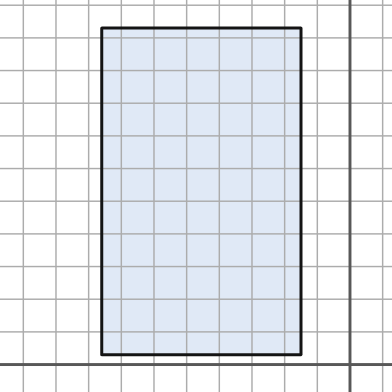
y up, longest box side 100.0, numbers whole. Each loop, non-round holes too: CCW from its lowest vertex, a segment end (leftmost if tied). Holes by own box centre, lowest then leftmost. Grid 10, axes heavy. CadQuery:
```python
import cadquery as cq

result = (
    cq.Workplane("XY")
    .moveTo(-76.0, 3.0)
    .lineTo(-15.0, 3.0)
    .lineTo(-15.0, 103.0)
    .lineTo(-76.0, 103.0)
    .close()
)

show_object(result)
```